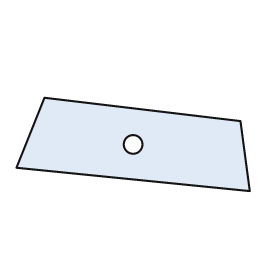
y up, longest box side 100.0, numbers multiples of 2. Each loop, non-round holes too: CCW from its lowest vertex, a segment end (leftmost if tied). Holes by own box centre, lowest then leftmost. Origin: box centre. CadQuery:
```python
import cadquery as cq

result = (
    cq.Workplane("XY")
    .moveTo(50.0, -20.0)
    .lineTo(46.0, 10.0)
    .lineTo(-38.0, 20.0)
    .lineTo(-50.0, -10.0)
    .close()
    .moveTo(0.0, 0.0)
    .circle(4.0)
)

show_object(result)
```